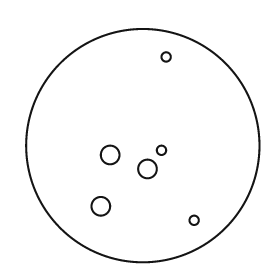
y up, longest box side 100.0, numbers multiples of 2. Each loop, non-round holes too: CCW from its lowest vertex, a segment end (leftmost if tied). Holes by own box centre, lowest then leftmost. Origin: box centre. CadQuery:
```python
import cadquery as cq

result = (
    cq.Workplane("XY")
    .moveTo(0.0, 0.0)
    .circle(50.0)
    .moveTo(22.0, -32.0)
    .circle(2.0)
    .moveTo(-18.0, -26.0)
    .circle(4.0)
    .moveTo(2.0, -10.0)
    .circle(4.0)
    .moveTo(-14.0, -4.0)
    .circle(4.0)
    .moveTo(8.0, -2.0)
    .circle(2.0)
    .moveTo(10.0, 38.0)
    .circle(2.0)
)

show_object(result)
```